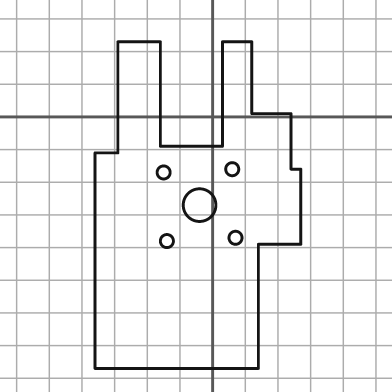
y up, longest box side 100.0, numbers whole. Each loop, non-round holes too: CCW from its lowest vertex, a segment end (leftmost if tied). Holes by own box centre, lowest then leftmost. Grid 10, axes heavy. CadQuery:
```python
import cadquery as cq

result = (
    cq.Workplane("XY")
    .moveTo(-36.0, -77.0)
    .lineTo(14.0, -77.0)
    .lineTo(14.0, -39.0)
    .lineTo(27.0, -39.0)
    .lineTo(27.0, -16.0)
    .lineTo(24.0, -16.0)
    .lineTo(24.0, 1.0)
    .lineTo(12.0, 1.0)
    .lineTo(12.0, 23.0)
    .lineTo(3.0, 23.0)
    .lineTo(3.0, -9.0)
    .lineTo(-16.0, -9.0)
    .lineTo(-16.0, 23.0)
    .lineTo(-29.0, 23.0)
    .lineTo(-29.0, -11.0)
    .lineTo(-36.0, -11.0)
    .close()
    .moveTo(-14.0, -38.0)
    .circle(2.0)
    .moveTo(7.0, -37.0)
    .circle(2.0)
    .moveTo(-4.0, -27.0)
    .circle(5.0)
    .moveTo(-15.0, -17.0)
    .circle(2.0)
    .moveTo(6.0, -16.0)
    .circle(2.0)
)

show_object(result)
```